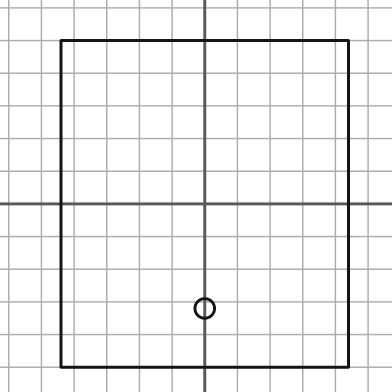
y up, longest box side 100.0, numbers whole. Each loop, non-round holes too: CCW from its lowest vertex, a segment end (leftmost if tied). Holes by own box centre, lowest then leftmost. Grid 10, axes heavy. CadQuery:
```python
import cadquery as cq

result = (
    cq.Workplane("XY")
    .moveTo(-44.0, -50.0)
    .lineTo(44.0, -50.0)
    .lineTo(44.0, 50.0)
    .lineTo(-44.0, 50.0)
    .close()
    .moveTo(0.0, -32.0)
    .circle(3.0)
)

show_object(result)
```